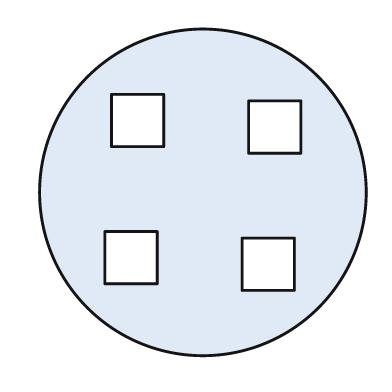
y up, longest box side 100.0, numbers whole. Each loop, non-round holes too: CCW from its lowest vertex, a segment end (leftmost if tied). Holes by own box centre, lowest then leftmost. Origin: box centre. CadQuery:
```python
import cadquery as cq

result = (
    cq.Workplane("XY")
    .moveTo(0.0, 0.0)
    .circle(50.0)
    .moveTo(12.0, -30.0)
    .lineTo(28.0, -30.0)
    .lineTo(28.0, -14.0)
    .lineTo(12.0, -14.0)
    .close()
    .moveTo(-30.0, -28.0)
    .lineTo(-14.0, -28.0)
    .lineTo(-14.0, -12.0)
    .lineTo(-30.0, -12.0)
    .close()
    .moveTo(14.0, 12.0)
    .lineTo(30.0, 12.0)
    .lineTo(30.0, 28.0)
    .lineTo(14.0, 28.0)
    .close()
    .moveTo(-28.0, 14.0)
    .lineTo(-12.0, 14.0)
    .lineTo(-12.0, 30.0)
    .lineTo(-28.0, 30.0)
    .close()
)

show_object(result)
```